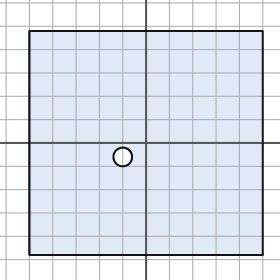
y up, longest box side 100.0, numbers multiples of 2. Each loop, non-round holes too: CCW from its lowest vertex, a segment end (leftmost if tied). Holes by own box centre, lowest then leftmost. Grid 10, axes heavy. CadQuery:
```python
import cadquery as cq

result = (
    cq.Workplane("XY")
    .moveTo(-50.0, -48.0)
    .lineTo(50.0, -48.0)
    .lineTo(50.0, 48.0)
    .lineTo(-50.0, 48.0)
    .close()
    .moveTo(-10.0, -6.0)
    .circle(4.0)
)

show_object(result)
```